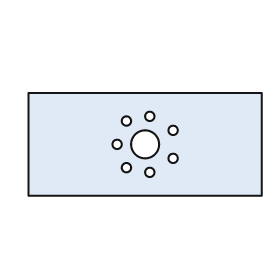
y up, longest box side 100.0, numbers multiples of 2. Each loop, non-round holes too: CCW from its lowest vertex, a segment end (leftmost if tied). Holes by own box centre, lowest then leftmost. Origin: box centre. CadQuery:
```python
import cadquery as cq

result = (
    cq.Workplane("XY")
    .moveTo(-50.0, -22.0)
    .lineTo(50.0, -22.0)
    .lineTo(50.0, 22.0)
    .lineTo(-50.0, 22.0)
    .close()
    .moveTo(2.0, -12.0)
    .circle(2.0)
    .moveTo(-8.0, -10.0)
    .circle(2.0)
    .moveTo(12.0, -6.0)
    .circle(2.0)
    .moveTo(-12.0, 0.0)
    .circle(2.0)
    .moveTo(0.0, 0.0)
    .circle(6.0)
    .moveTo(12.0, 6.0)
    .circle(2.0)
    .moveTo(-8.0, 10.0)
    .circle(2.0)
    .moveTo(2.0, 12.0)
    .circle(2.0)
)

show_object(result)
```